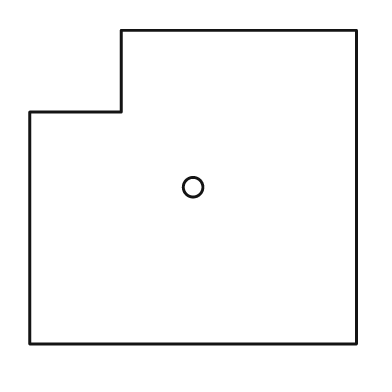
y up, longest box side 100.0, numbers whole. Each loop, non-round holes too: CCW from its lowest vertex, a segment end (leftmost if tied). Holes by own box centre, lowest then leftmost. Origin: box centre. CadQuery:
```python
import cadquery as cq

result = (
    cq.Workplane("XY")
    .moveTo(-50.0, -48.0)
    .lineTo(50.0, -48.0)
    .lineTo(50.0, 48.0)
    .lineTo(-22.0, 48.0)
    .lineTo(-22.0, 23.0)
    .lineTo(-50.0, 23.0)
    .close()
    .moveTo(0.0, 0.0)
    .circle(3.0)
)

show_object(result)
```